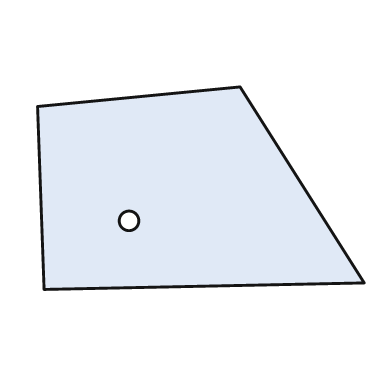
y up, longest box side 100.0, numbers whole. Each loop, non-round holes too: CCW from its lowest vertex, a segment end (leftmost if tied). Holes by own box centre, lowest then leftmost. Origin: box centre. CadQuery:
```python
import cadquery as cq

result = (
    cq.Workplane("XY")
    .moveTo(-48.0, -31.0)
    .lineTo(50.0, -29.0)
    .lineTo(12.0, 31.0)
    .lineTo(-50.0, 25.0)
    .close()
    .moveTo(-22.0, -10.0)
    .circle(3.0)
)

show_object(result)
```